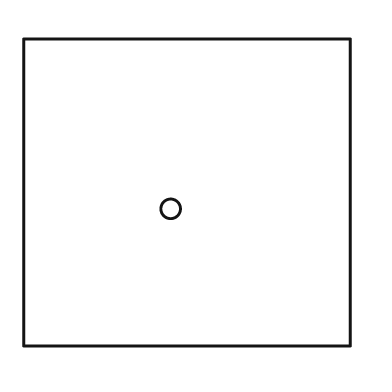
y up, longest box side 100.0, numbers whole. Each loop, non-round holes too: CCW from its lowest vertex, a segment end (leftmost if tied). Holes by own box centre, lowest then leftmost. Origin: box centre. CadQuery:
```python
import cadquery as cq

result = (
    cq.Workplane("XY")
    .moveTo(-50.0, -47.0)
    .lineTo(50.0, -47.0)
    .lineTo(50.0, 47.0)
    .lineTo(-50.0, 47.0)
    .close()
    .moveTo(-5.0, -5.0)
    .circle(3.0)
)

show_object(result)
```